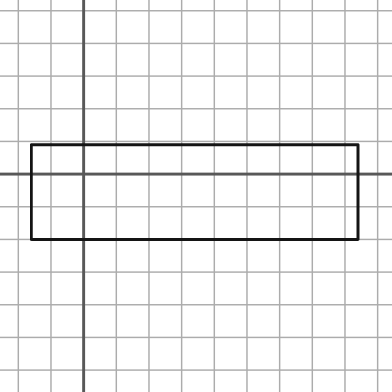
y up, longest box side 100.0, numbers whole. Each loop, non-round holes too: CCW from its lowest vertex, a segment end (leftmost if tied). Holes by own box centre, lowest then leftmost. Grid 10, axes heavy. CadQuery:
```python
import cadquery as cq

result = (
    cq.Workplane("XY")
    .moveTo(-16.0, -20.0)
    .lineTo(84.0, -20.0)
    .lineTo(84.0, 9.0)
    .lineTo(-16.0, 9.0)
    .close()
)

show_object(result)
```